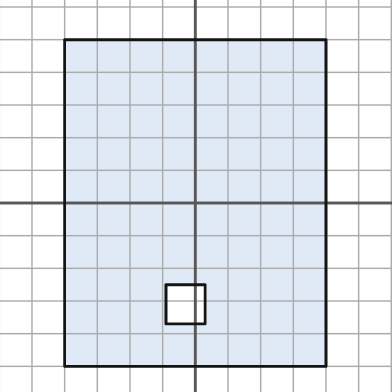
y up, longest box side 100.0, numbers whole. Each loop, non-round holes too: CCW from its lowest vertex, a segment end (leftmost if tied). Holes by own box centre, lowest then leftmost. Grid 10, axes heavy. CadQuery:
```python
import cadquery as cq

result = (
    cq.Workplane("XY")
    .moveTo(-40.0, -50.0)
    .lineTo(40.0, -50.0)
    .lineTo(40.0, 50.0)
    .lineTo(-40.0, 50.0)
    .close()
    .moveTo(-9.0, -37.0)
    .lineTo(3.0, -37.0)
    .lineTo(3.0, -25.0)
    .lineTo(-9.0, -25.0)
    .close()
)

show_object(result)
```